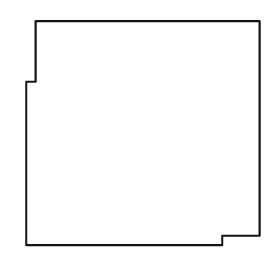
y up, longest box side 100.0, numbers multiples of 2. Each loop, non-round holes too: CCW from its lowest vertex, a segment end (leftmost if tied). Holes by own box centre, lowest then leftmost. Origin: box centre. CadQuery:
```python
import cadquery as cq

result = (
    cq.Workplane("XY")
    .moveTo(-50.0, -48.0)
    .lineTo(34.0, -48.0)
    .lineTo(34.0, -44.0)
    .lineTo(50.0, -44.0)
    .lineTo(50.0, 48.0)
    .lineTo(-46.0, 48.0)
    .lineTo(-46.0, 22.0)
    .lineTo(-50.0, 22.0)
    .close()
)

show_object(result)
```